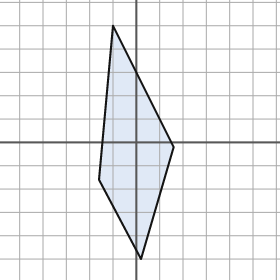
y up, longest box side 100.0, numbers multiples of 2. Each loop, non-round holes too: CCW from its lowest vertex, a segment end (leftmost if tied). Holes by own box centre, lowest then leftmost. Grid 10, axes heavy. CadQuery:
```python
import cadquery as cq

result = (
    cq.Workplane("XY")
    .moveTo(2.0, -50.0)
    .lineTo(16.0, -2.0)
    .lineTo(-10.0, 50.0)
    .lineTo(-16.0, -16.0)
    .close()
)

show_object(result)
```